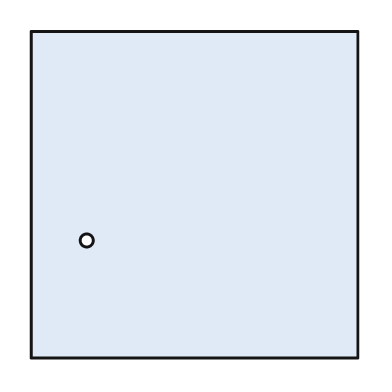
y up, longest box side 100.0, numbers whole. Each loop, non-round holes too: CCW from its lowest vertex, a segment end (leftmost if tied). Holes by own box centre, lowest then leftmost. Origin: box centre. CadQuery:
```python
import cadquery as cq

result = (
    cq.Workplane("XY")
    .moveTo(-50.0, -50.0)
    .lineTo(50.0, -50.0)
    .lineTo(50.0, 50.0)
    .lineTo(-50.0, 50.0)
    .close()
    .moveTo(-33.0, -14.0)
    .circle(2.0)
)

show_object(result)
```